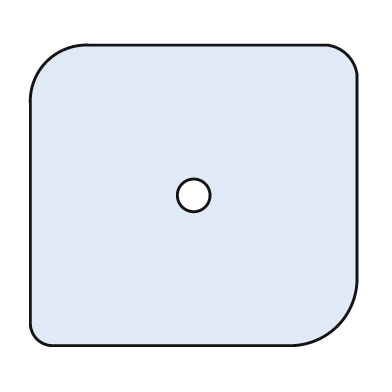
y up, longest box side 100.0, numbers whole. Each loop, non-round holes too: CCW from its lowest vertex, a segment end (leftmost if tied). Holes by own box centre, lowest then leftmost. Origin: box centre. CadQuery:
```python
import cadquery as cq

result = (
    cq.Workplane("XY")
    .moveTo(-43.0, -46.0)
    .lineTo(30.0, -46.0)
    .threePointArc((44.0, -40.0), (50.0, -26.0))
    .lineTo(50.0, 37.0)
    .threePointArc((47.0, 43.0), (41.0, 46.0))
    .lineTo(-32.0, 46.0)
    .threePointArc((-45.0, 41.0), (-50.0, 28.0))
    .lineTo(-50.0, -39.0)
    .threePointArc((-48.0, -44.0), (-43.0, -46.0))
    .close()
    .moveTo(0.0, 0.0)
    .circle(5.0)
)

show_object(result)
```